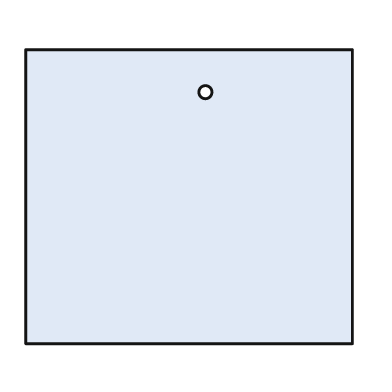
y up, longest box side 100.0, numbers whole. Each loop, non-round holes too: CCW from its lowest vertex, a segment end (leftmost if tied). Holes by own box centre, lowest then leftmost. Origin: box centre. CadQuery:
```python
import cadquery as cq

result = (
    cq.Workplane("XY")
    .moveTo(-50.0, -45.0)
    .lineTo(50.0, -45.0)
    .lineTo(50.0, 45.0)
    .lineTo(-50.0, 45.0)
    .close()
    .moveTo(5.0, 32.0)
    .circle(2.0)
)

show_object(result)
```